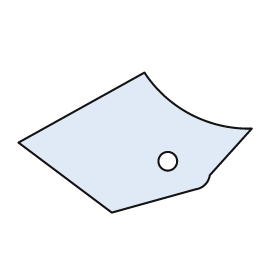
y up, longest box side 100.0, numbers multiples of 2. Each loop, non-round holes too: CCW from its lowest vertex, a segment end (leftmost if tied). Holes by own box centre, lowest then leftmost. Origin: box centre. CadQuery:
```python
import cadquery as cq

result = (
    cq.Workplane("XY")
    .moveTo(-10.0, -30.0)
    .lineTo(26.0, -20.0)
    .threePointArc((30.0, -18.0), (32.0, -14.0))
    .lineTo(50.0, 6.0)
    .threePointArc((24.0, 12.0), (4.0, 30.0))
    .lineTo(-50.0, 0.0)
    .close()
    .moveTo(14.0, -8.0)
    .circle(4.0)
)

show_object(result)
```